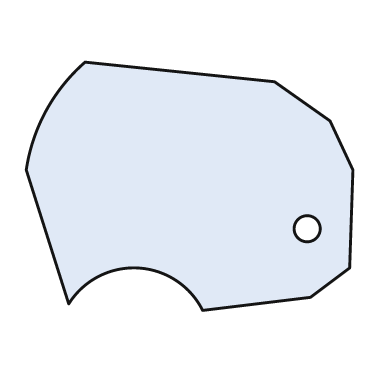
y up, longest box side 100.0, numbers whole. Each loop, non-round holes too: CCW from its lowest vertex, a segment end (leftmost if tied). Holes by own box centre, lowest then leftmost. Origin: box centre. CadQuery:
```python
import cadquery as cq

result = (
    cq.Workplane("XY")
    .moveTo(4.0, -38.0)
    .lineTo(37.0, -34.0)
    .lineTo(49.0, -25.0)
    .lineTo(50.0, 5.0)
    .lineTo(43.0, 20.0)
    .lineTo(26.0, 32.0)
    .lineTo(-32.0, 38.0)
    .threePointArc((-44.0, 23.0), (-50.0, 5.0))
    .lineTo(-37.0, -36.0)
    .threePointArc((-16.0, -25.0), (4.0, -38.0))
    .close()
    .moveTo(36.0, -13.0)
    .circle(4.0)
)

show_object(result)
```